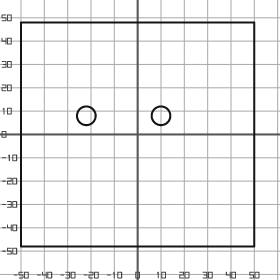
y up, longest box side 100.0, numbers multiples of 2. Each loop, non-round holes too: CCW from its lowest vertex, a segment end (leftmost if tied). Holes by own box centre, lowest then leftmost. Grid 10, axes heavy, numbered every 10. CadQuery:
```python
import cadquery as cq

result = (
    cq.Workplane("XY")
    .moveTo(-50.0, -48.0)
    .lineTo(50.0, -48.0)
    .lineTo(50.0, 48.0)
    .lineTo(-50.0, 48.0)
    .close()
    .moveTo(-22.0, 8.0)
    .circle(4.0)
    .moveTo(10.0, 8.0)
    .circle(4.0)
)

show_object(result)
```